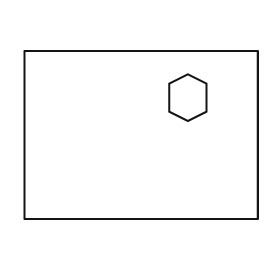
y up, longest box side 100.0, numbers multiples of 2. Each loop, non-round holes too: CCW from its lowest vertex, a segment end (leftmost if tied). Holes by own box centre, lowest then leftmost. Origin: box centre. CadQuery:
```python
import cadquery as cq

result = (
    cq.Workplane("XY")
    .moveTo(-50.0, -36.0)
    .lineTo(50.0, -36.0)
    .lineTo(50.0, 36.0)
    .lineTo(-50.0, 36.0)
    .close()
    .moveTo(20.0, 6.0)
    .lineTo(28.0, 10.0)
    .lineTo(28.0, 22.0)
    .lineTo(20.0, 26.0)
    .lineTo(12.0, 22.0)
    .lineTo(12.0, 10.0)
    .close()
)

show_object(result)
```